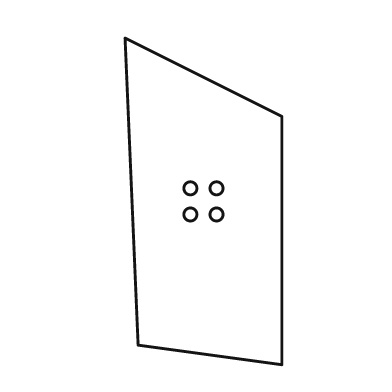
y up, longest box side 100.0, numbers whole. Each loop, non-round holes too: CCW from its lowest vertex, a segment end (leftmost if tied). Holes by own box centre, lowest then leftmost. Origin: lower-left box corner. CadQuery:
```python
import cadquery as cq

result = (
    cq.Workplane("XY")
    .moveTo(48.0, 0.0)
    .lineTo(48.0, 76.0)
    .lineTo(0.0, 100.0)
    .lineTo(4.0, 6.0)
    .close()
    .moveTo(20.0, 46.0)
    .circle(2.0)
    .moveTo(28.0, 46.0)
    .circle(2.0)
    .moveTo(20.0, 54.0)
    .circle(2.0)
    .moveTo(28.0, 54.0)
    .circle(2.0)
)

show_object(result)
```